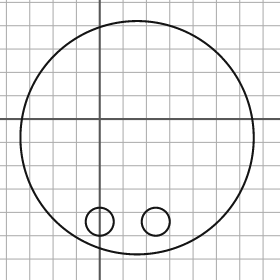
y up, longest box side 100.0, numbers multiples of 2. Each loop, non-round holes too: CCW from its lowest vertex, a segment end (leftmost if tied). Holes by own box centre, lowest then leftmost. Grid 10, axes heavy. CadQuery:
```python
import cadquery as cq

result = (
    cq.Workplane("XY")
    .moveTo(16.0, -8.0)
    .circle(50.0)
    .moveTo(0.0, -44.0)
    .circle(6.0)
    .moveTo(24.0, -44.0)
    .circle(6.0)
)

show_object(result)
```